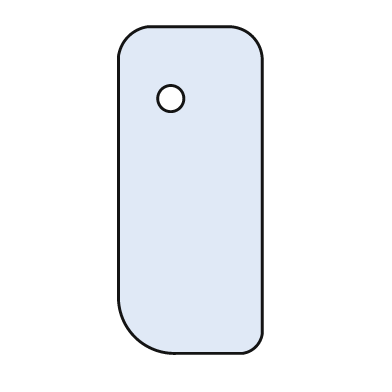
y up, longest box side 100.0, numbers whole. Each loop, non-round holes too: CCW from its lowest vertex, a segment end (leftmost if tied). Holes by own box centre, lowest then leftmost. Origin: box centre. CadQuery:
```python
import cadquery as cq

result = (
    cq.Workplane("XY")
    .moveTo(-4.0, -50.0)
    .lineTo(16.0, -50.0)
    .threePointArc((20.0, -48.0), (22.0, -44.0))
    .lineTo(22.0, 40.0)
    .threePointArc((19.0, 47.0), (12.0, 50.0))
    .lineTo(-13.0, 50.0)
    .threePointArc((-19.0, 47.0), (-22.0, 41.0))
    .lineTo(-22.0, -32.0)
    .threePointArc((-17.0, -45.0), (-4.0, -50.0))
    .close()
    .moveTo(-6.0, 28.0)
    .circle(4.0)
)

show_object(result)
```